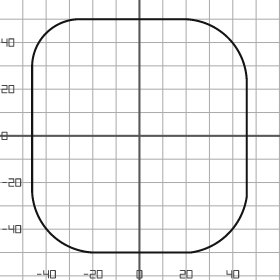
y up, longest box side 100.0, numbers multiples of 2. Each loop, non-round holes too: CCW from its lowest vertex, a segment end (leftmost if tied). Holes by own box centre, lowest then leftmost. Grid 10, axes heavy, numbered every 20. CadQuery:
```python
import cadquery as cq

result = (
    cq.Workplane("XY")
    .moveTo(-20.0, -50.0)
    .lineTo(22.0, -50.0)
    .threePointArc((38.0, -42.0), (46.0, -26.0))
    .lineTo(46.0, 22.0)
    .threePointArc((38.0, 42.0), (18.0, 50.0))
    .lineTo(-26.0, 50.0)
    .threePointArc((-40.0, 44.0), (-46.0, 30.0))
    .lineTo(-46.0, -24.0)
    .threePointArc((-38.0, -42.0), (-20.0, -50.0))
    .close()
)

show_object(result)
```